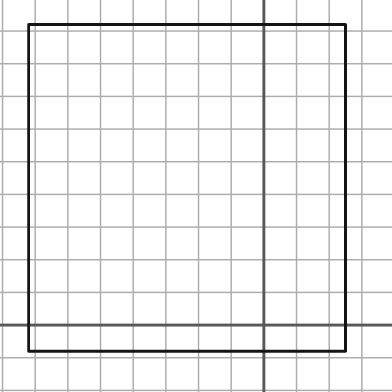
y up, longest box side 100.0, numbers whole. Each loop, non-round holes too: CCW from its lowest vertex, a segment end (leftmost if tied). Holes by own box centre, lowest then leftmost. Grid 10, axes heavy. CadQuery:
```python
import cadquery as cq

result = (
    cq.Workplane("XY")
    .moveTo(-72.0, -8.0)
    .lineTo(25.0, -8.0)
    .lineTo(25.0, 92.0)
    .lineTo(-72.0, 92.0)
    .close()
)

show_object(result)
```